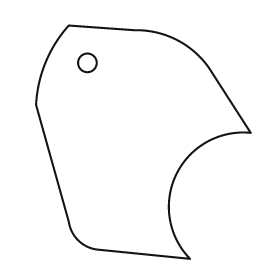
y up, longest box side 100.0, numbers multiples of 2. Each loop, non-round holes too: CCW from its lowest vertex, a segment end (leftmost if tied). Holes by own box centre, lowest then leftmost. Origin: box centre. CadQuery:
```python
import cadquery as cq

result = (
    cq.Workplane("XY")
    .moveTo(20.0, -50.0)
    .threePointArc((14.0, -14.0), (46.0, 4.0))
    .lineTo(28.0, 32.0)
    .threePointArc((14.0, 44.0), (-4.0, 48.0))
    .lineTo(-32.0, 50.0)
    .threePointArc((-42.0, 34.0), (-46.0, 16.0))
    .lineTo(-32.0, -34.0)
    .threePointArc((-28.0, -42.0), (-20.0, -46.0))
    .close()
    .moveTo(-24.0, 34.0)
    .circle(4.0)
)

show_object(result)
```